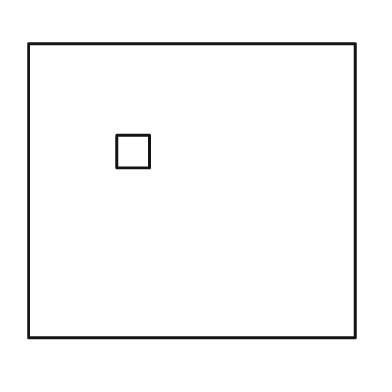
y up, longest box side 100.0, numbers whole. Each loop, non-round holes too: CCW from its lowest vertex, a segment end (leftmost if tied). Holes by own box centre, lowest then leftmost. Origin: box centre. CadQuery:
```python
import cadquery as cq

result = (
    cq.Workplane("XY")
    .moveTo(-50.0, -45.0)
    .lineTo(50.0, -45.0)
    .lineTo(50.0, 45.0)
    .lineTo(-50.0, 45.0)
    .close()
    .moveTo(-23.0, 7.0)
    .lineTo(-13.0, 7.0)
    .lineTo(-13.0, 17.0)
    .lineTo(-23.0, 17.0)
    .close()
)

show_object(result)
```